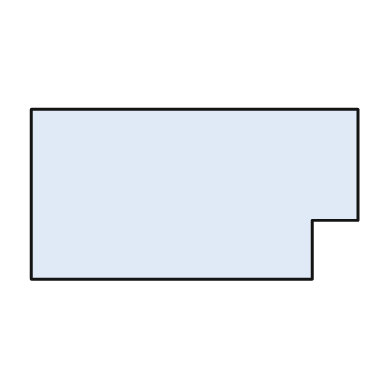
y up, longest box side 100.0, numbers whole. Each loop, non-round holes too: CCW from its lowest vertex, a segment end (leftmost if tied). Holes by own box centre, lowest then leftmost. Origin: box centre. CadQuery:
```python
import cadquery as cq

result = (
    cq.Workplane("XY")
    .moveTo(-50.0, -26.0)
    .lineTo(36.0, -26.0)
    .lineTo(36.0, -8.0)
    .lineTo(50.0, -8.0)
    .lineTo(50.0, 26.0)
    .lineTo(-50.0, 26.0)
    .close()
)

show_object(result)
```